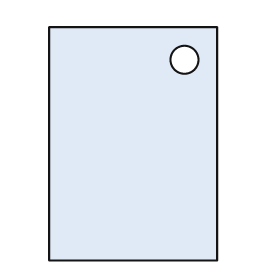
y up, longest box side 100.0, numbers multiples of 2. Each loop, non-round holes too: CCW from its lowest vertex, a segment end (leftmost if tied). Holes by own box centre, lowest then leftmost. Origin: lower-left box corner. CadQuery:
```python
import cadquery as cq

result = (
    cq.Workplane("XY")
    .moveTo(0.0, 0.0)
    .lineTo(72.0, 0.0)
    .lineTo(72.0, 100.0)
    .lineTo(0.0, 100.0)
    .close()
    .moveTo(58.0, 86.0)
    .circle(6.0)
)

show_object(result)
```